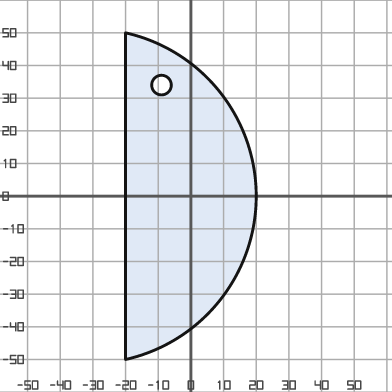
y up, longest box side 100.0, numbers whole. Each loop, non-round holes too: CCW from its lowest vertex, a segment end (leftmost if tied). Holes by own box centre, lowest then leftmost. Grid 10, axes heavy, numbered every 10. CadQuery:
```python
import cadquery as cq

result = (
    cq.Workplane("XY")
    .moveTo(-20.0, -50.0)
    .threePointArc((20.0, 0.0), (-20.0, 50.0))
    .close()
    .moveTo(-9.0, 34.0)
    .circle(3.0)
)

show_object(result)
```